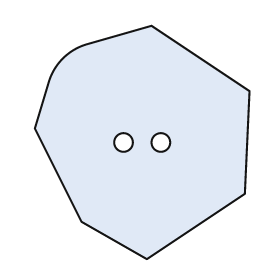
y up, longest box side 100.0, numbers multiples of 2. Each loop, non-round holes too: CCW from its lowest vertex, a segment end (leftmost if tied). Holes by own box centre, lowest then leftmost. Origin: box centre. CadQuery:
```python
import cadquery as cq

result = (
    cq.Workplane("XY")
    .moveTo(2.0, -50.0)
    .lineTo(44.0, -22.0)
    .lineTo(46.0, 22.0)
    .lineTo(4.0, 50.0)
    .lineTo(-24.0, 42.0)
    .threePointArc((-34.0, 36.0), (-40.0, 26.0))
    .lineTo(-46.0, 6.0)
    .lineTo(-26.0, -34.0)
    .close()
    .moveTo(-8.0, 0.0)
    .circle(4.0)
    .moveTo(8.0, 0.0)
    .circle(4.0)
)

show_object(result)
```